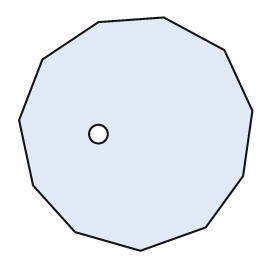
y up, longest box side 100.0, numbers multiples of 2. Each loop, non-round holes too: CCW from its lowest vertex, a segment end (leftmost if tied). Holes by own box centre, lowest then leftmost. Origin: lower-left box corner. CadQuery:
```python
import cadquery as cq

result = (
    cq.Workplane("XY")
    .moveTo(52.0, 0.0)
    .lineTo(80.0, 10.0)
    .lineTo(96.0, 32.0)
    .lineTo(100.0, 60.0)
    .lineTo(88.0, 86.0)
    .lineTo(62.0, 100.0)
    .lineTo(34.0, 98.0)
    .lineTo(10.0, 82.0)
    .lineTo(0.0, 56.0)
    .lineTo(6.0, 28.0)
    .lineTo(24.0, 8.0)
    .close()
    .moveTo(34.0, 50.0)
    .circle(4.0)
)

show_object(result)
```